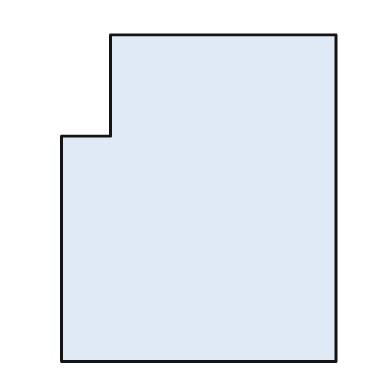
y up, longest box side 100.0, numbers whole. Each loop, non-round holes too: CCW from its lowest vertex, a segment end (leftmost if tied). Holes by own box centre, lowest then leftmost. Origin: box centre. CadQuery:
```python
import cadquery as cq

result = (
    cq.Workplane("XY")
    .moveTo(-42.0, -50.0)
    .lineTo(42.0, -50.0)
    .lineTo(42.0, 50.0)
    .lineTo(-27.0, 50.0)
    .lineTo(-27.0, 19.0)
    .lineTo(-42.0, 19.0)
    .close()
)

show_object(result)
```